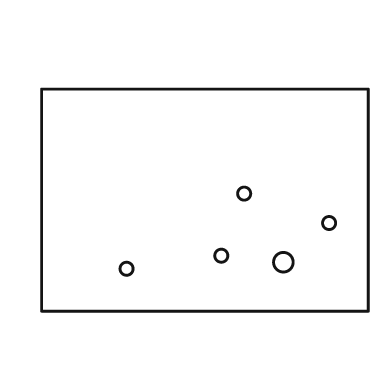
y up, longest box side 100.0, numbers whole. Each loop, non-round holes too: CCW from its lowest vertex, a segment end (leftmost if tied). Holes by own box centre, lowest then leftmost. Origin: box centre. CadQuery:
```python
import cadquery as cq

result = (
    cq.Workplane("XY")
    .moveTo(-50.0, -34.0)
    .lineTo(50.0, -34.0)
    .lineTo(50.0, 34.0)
    .lineTo(-50.0, 34.0)
    .close()
    .moveTo(-24.0, -21.0)
    .circle(2.0)
    .moveTo(24.0, -19.0)
    .circle(3.0)
    .moveTo(5.0, -17.0)
    .circle(2.0)
    .moveTo(38.0, -7.0)
    .circle(2.0)
    .moveTo(12.0, 2.0)
    .circle(2.0)
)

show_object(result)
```